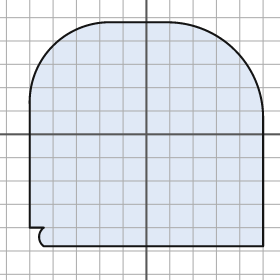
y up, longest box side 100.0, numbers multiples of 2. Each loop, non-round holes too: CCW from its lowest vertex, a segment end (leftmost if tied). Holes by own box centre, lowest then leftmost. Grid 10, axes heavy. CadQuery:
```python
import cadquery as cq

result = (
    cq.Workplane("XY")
    .moveTo(-44.0, -48.0)
    .lineTo(50.0, -48.0)
    .lineTo(50.0, 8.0)
    .threePointArc((38.0, 36.0), (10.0, 48.0))
    .lineTo(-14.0, 48.0)
    .threePointArc((-40.0, 38.0), (-50.0, 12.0))
    .lineTo(-50.0, -40.0)
    .lineTo(-44.0, -40.0)
    .threePointArc((-46.0, -44.0), (-44.0, -48.0))
    .close()
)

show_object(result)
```